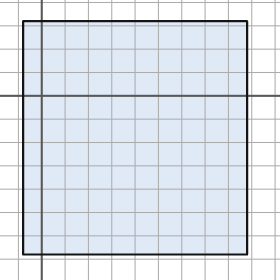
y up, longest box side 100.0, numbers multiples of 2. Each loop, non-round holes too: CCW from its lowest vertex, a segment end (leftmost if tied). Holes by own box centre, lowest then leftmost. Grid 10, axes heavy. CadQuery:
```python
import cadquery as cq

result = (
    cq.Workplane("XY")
    .moveTo(-8.0, -68.0)
    .lineTo(88.0, -68.0)
    .lineTo(88.0, 32.0)
    .lineTo(-8.0, 32.0)
    .close()
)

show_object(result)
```